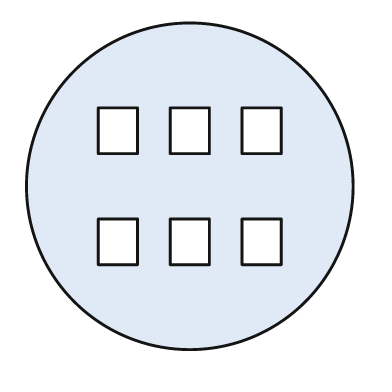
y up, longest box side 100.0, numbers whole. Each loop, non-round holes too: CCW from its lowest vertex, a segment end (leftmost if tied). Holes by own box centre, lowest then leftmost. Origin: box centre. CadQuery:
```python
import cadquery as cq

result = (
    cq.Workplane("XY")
    .moveTo(0.0, 0.0)
    .circle(50.0)
    .moveTo(-28.0, -24.0)
    .lineTo(-16.0, -24.0)
    .lineTo(-16.0, -10.0)
    .lineTo(-28.0, -10.0)
    .close()
    .moveTo(-6.0, -24.0)
    .lineTo(6.0, -24.0)
    .lineTo(6.0, -10.0)
    .lineTo(-6.0, -10.0)
    .close()
    .moveTo(16.0, -24.0)
    .lineTo(28.0, -24.0)
    .lineTo(28.0, -10.0)
    .lineTo(16.0, -10.0)
    .close()
    .moveTo(-28.0, 10.0)
    .lineTo(-16.0, 10.0)
    .lineTo(-16.0, 24.0)
    .lineTo(-28.0, 24.0)
    .close()
    .moveTo(-6.0, 10.0)
    .lineTo(6.0, 10.0)
    .lineTo(6.0, 24.0)
    .lineTo(-6.0, 24.0)
    .close()
    .moveTo(16.0, 10.0)
    .lineTo(28.0, 10.0)
    .lineTo(28.0, 24.0)
    .lineTo(16.0, 24.0)
    .close()
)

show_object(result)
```